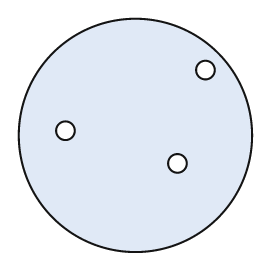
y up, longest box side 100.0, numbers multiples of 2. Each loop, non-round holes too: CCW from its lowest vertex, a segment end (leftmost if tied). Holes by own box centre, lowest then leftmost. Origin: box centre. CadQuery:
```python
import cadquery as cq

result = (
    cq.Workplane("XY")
    .moveTo(0.0, 0.0)
    .circle(50.0)
    .moveTo(18.0, -12.0)
    .circle(4.0)
    .moveTo(-30.0, 2.0)
    .circle(4.0)
    .moveTo(30.0, 28.0)
    .circle(4.0)
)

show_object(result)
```